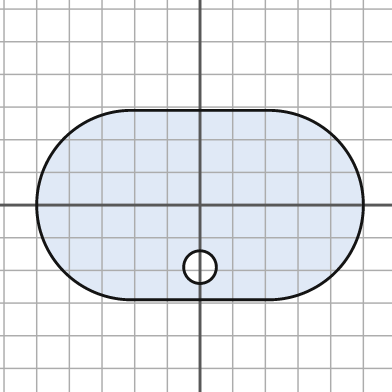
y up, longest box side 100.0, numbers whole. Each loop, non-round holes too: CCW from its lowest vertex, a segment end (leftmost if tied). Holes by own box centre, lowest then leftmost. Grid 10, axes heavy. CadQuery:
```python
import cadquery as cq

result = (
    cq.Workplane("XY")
    .moveTo(-21.0, -29.0)
    .lineTo(21.0, -29.0)
    .threePointArc((50.0, 0.0), (21.0, 29.0))
    .lineTo(-21.0, 29.0)
    .threePointArc((-50.0, 0.0), (-21.0, -29.0))
    .close()
    .moveTo(0.0, -19.0)
    .circle(5.0)
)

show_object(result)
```